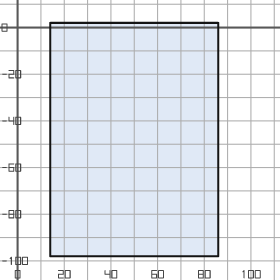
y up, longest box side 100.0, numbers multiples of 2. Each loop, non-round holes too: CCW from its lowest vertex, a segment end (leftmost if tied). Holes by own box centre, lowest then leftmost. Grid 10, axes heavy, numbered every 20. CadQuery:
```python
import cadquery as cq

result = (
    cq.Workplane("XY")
    .moveTo(14.0, -98.0)
    .lineTo(86.0, -98.0)
    .lineTo(86.0, 2.0)
    .lineTo(14.0, 2.0)
    .close()
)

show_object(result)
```